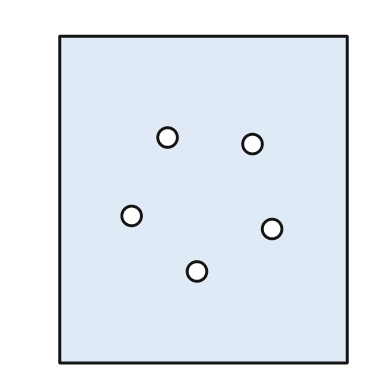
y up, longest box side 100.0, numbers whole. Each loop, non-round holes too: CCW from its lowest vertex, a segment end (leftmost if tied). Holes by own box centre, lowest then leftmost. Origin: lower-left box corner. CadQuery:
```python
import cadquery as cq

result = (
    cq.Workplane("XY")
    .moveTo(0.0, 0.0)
    .lineTo(88.0, 0.0)
    .lineTo(88.0, 100.0)
    .lineTo(0.0, 100.0)
    .close()
    .moveTo(42.0, 28.0)
    .circle(3.0)
    .moveTo(65.0, 41.0)
    .circle(3.0)
    .moveTo(22.0, 45.0)
    .circle(3.0)
    .moveTo(59.0, 67.0)
    .circle(3.0)
    .moveTo(33.0, 69.0)
    .circle(3.0)
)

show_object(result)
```